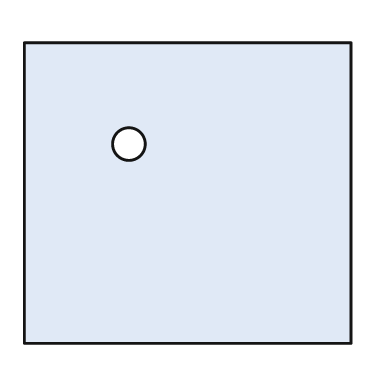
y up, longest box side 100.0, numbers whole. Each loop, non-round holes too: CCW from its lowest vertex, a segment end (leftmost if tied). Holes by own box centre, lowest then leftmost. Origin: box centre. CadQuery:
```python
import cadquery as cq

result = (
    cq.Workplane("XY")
    .moveTo(-50.0, -46.0)
    .lineTo(50.0, -46.0)
    .lineTo(50.0, 46.0)
    .lineTo(-50.0, 46.0)
    .close()
    .moveTo(-18.0, 15.0)
    .circle(5.0)
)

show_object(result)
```